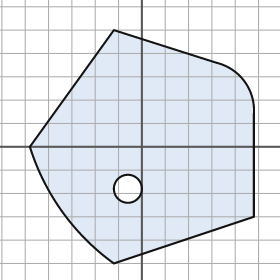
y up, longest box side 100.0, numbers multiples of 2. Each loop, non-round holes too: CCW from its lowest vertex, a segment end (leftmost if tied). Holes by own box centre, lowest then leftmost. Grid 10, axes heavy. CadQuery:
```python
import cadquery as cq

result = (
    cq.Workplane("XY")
    .moveTo(-12.0, -50.0)
    .lineTo(48.0, -30.0)
    .lineTo(48.0, 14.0)
    .threePointArc((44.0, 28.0), (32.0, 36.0))
    .lineTo(-12.0, 50.0)
    .lineTo(-48.0, 0.0)
    .threePointArc((-34.0, -28.0), (-12.0, -50.0))
    .close()
    .moveTo(-6.0, -18.0)
    .circle(6.0)
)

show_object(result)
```